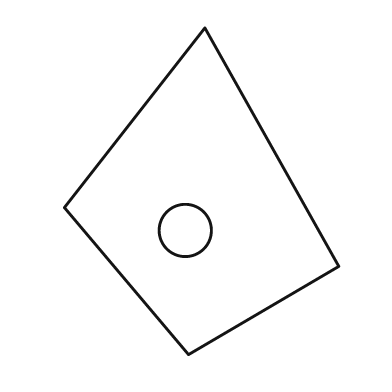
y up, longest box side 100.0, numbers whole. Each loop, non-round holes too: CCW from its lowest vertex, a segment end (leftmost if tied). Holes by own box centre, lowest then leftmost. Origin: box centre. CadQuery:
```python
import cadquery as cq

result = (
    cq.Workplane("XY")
    .moveTo(-4.0, -50.0)
    .lineTo(42.0, -23.0)
    .lineTo(1.0, 50.0)
    .lineTo(-42.0, -5.0)
    .close()
    .moveTo(-5.0, -12.0)
    .circle(8.0)
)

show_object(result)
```